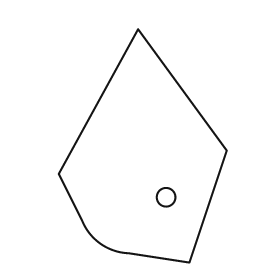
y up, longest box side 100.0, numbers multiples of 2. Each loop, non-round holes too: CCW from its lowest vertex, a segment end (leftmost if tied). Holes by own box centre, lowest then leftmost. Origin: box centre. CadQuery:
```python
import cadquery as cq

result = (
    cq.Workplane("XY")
    .moveTo(20.0, -50.0)
    .lineTo(36.0, -2.0)
    .lineTo(-2.0, 50.0)
    .lineTo(-36.0, -12.0)
    .lineTo(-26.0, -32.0)
    .threePointArc((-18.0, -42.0), (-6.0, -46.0))
    .close()
    .moveTo(10.0, -22.0)
    .circle(4.0)
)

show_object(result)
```